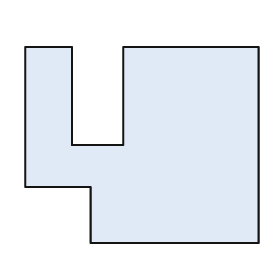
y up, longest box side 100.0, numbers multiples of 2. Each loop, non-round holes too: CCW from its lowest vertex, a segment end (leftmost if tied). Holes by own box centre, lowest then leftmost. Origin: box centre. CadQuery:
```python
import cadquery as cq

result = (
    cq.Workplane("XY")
    .moveTo(-22.0, -42.0)
    .lineTo(50.0, -42.0)
    .lineTo(50.0, 42.0)
    .lineTo(-8.0, 42.0)
    .lineTo(-8.0, 0.0)
    .lineTo(-30.0, 0.0)
    .lineTo(-30.0, 42.0)
    .lineTo(-50.0, 42.0)
    .lineTo(-50.0, -18.0)
    .lineTo(-22.0, -18.0)
    .close()
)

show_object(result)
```